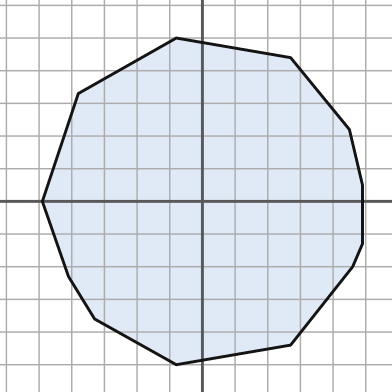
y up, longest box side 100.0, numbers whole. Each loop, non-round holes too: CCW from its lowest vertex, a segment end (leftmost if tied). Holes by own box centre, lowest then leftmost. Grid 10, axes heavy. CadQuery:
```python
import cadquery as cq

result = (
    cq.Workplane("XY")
    .moveTo(-8.0, -50.0)
    .lineTo(27.0, -44.0)
    .lineTo(46.0, -20.0)
    .lineTo(49.0, -13.0)
    .lineTo(49.0, 5.0)
    .lineTo(45.0, 22.0)
    .lineTo(27.0, 44.0)
    .lineTo(-8.0, 50.0)
    .lineTo(-38.0, 33.0)
    .lineTo(-49.0, 0.0)
    .lineTo(-41.0, -23.0)
    .lineTo(-33.0, -36.0)
    .close()
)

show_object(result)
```